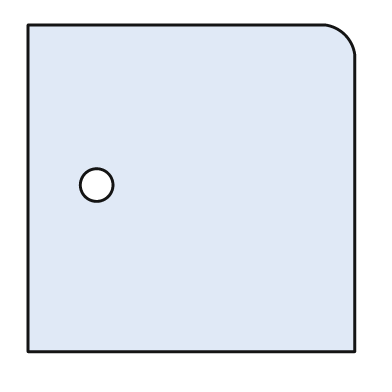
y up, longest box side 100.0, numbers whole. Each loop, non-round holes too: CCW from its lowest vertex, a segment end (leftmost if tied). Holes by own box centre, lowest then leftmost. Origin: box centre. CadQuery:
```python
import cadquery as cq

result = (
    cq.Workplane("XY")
    .moveTo(-50.0, -50.0)
    .lineTo(50.0, -50.0)
    .lineTo(50.0, 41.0)
    .threePointArc((47.0, 47.0), (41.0, 50.0))
    .lineTo(-50.0, 50.0)
    .close()
    .moveTo(-29.0, 1.0)
    .circle(5.0)
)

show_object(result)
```